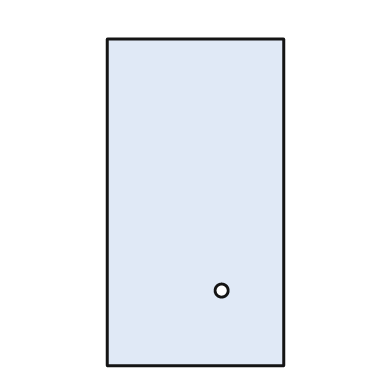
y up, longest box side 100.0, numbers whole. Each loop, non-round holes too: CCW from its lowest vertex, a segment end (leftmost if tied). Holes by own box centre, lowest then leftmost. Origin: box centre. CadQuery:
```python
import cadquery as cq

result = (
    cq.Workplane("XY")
    .moveTo(-27.0, -50.0)
    .lineTo(27.0, -50.0)
    .lineTo(27.0, 50.0)
    .lineTo(-27.0, 50.0)
    .close()
    .moveTo(8.0, -27.0)
    .circle(2.0)
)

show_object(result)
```